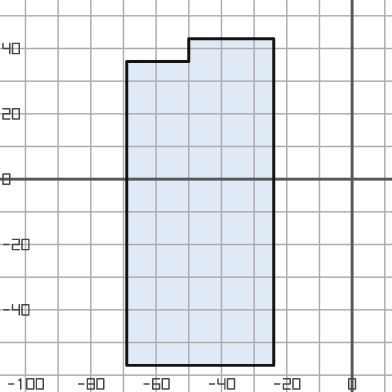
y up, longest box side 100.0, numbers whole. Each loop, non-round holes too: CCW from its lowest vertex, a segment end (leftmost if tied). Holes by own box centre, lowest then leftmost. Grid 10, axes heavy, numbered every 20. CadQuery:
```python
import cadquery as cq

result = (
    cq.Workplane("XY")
    .moveTo(-69.0, -57.0)
    .lineTo(-24.0, -57.0)
    .lineTo(-24.0, 43.0)
    .lineTo(-50.0, 43.0)
    .lineTo(-50.0, 36.0)
    .lineTo(-69.0, 36.0)
    .close()
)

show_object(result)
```